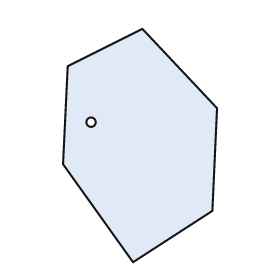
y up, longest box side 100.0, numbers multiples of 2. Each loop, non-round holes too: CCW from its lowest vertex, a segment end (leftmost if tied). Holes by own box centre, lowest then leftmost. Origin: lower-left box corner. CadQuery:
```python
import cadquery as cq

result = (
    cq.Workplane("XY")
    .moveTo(30.0, 0.0)
    .lineTo(64.0, 22.0)
    .lineTo(66.0, 66.0)
    .lineTo(34.0, 100.0)
    .lineTo(2.0, 84.0)
    .lineTo(0.0, 42.0)
    .close()
    .moveTo(12.0, 60.0)
    .circle(2.0)
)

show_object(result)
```